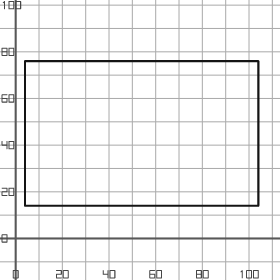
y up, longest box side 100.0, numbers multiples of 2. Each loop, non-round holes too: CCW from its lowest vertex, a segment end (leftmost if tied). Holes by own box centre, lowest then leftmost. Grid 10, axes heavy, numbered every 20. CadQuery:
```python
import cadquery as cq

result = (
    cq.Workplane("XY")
    .moveTo(4.0, 14.0)
    .lineTo(104.0, 14.0)
    .lineTo(104.0, 76.0)
    .lineTo(4.0, 76.0)
    .close()
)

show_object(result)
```